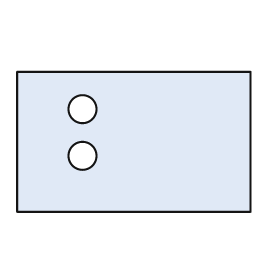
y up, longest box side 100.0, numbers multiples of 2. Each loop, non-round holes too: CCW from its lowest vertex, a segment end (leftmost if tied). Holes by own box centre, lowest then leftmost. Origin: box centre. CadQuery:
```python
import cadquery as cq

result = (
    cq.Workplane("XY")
    .moveTo(-50.0, -30.0)
    .lineTo(50.0, -30.0)
    .lineTo(50.0, 30.0)
    .lineTo(-50.0, 30.0)
    .close()
    .moveTo(-22.0, -6.0)
    .circle(6.0)
    .moveTo(-22.0, 14.0)
    .circle(6.0)
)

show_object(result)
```